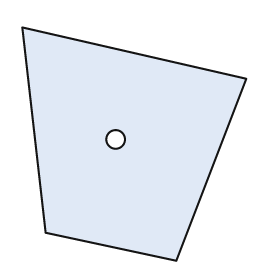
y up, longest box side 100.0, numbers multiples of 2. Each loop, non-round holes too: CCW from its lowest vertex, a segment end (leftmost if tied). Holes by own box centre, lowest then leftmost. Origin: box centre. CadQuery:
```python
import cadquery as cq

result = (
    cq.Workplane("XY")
    .moveTo(18.0, -50.0)
    .lineTo(48.0, 28.0)
    .lineTo(-48.0, 50.0)
    .lineTo(-38.0, -38.0)
    .close()
    .moveTo(-8.0, 2.0)
    .circle(4.0)
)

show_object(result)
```